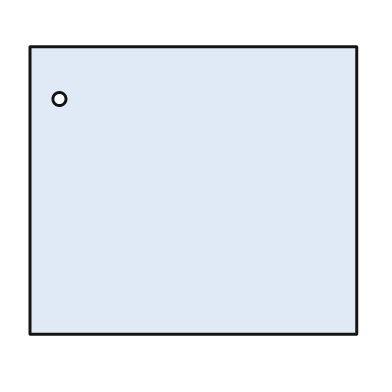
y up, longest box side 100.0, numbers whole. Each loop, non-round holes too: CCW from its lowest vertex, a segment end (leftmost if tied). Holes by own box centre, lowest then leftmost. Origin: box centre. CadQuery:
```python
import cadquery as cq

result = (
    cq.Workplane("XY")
    .moveTo(-50.0, -44.0)
    .lineTo(50.0, -44.0)
    .lineTo(50.0, 44.0)
    .lineTo(-50.0, 44.0)
    .close()
    .moveTo(-41.0, 28.0)
    .circle(2.0)
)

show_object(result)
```